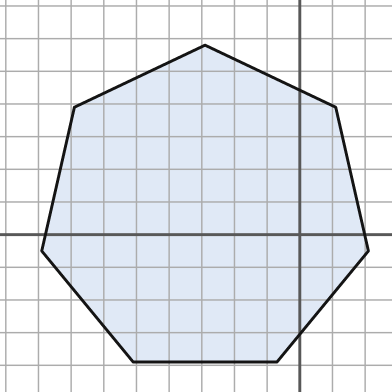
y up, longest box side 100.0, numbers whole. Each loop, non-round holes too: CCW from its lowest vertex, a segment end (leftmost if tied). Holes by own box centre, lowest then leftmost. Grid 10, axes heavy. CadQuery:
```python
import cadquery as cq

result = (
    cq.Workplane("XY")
    .moveTo(-51.0, -39.0)
    .lineTo(-7.0, -39.0)
    .lineTo(21.0, -5.0)
    .lineTo(11.0, 39.0)
    .lineTo(-29.0, 58.0)
    .lineTo(-69.0, 39.0)
    .lineTo(-79.0, -5.0)
    .close()
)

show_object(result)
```